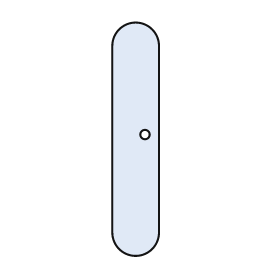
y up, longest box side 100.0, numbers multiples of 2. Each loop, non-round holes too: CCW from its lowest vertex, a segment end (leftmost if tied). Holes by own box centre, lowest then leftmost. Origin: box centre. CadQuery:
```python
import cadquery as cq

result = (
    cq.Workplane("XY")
    .moveTo(-10.0, -40.0)
    .threePointArc((0.0, -50.0), (10.0, -40.0))
    .lineTo(10.0, 40.0)
    .threePointArc((0.0, 50.0), (-10.0, 40.0))
    .close()
    .moveTo(4.0, 2.0)
    .circle(2.0)
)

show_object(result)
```